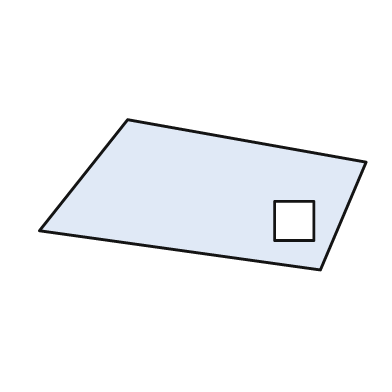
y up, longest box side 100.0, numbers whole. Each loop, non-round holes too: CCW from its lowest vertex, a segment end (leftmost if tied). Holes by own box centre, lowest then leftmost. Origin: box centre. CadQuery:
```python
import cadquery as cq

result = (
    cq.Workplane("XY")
    .moveTo(36.0, -23.0)
    .lineTo(50.0, 10.0)
    .lineTo(-23.0, 23.0)
    .lineTo(-50.0, -11.0)
    .close()
    .moveTo(22.0, -14.0)
    .lineTo(34.0, -14.0)
    .lineTo(34.0, -2.0)
    .lineTo(22.0, -2.0)
    .close()
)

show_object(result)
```